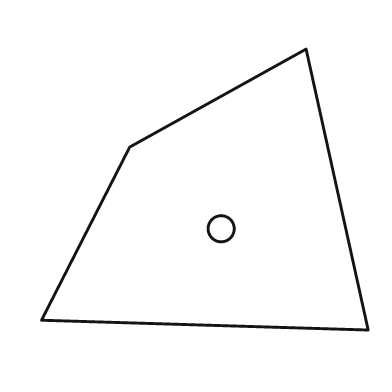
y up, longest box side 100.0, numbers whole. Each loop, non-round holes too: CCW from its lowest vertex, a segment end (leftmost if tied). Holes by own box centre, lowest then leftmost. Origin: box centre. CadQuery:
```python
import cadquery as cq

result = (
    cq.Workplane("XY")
    .moveTo(50.0, -43.0)
    .lineTo(31.0, 43.0)
    .lineTo(-23.0, 13.0)
    .lineTo(-50.0, -40.0)
    .close()
    .moveTo(5.0, -12.0)
    .circle(4.0)
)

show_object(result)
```